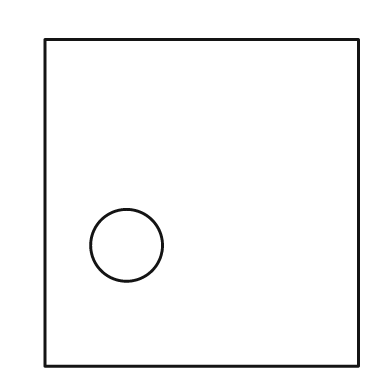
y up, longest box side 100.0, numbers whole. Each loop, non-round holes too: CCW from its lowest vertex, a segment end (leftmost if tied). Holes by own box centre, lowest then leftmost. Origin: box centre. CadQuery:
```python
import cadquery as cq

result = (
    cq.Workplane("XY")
    .moveTo(-48.0, -50.0)
    .lineTo(48.0, -50.0)
    .lineTo(48.0, 50.0)
    .lineTo(-48.0, 50.0)
    .close()
    .moveTo(-23.0, -13.0)
    .circle(11.0)
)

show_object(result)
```